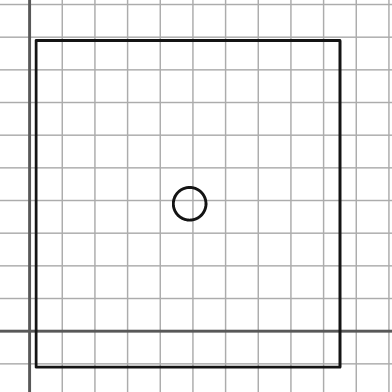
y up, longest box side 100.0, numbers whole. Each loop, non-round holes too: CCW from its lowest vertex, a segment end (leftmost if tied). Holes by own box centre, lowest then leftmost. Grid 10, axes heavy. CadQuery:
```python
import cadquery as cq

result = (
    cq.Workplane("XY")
    .moveTo(2.0, -11.0)
    .lineTo(95.0, -11.0)
    .lineTo(95.0, 89.0)
    .lineTo(2.0, 89.0)
    .close()
    .moveTo(49.0, 39.0)
    .circle(5.0)
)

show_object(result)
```